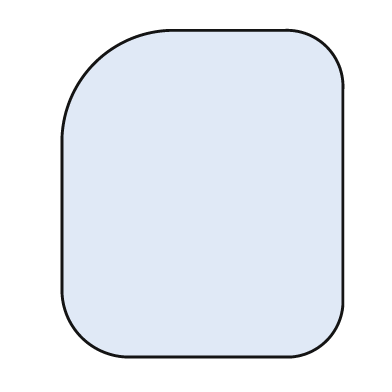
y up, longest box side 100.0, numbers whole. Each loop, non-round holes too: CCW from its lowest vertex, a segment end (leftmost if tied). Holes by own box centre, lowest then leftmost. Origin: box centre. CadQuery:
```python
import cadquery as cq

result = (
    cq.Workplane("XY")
    .moveTo(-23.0, -50.0)
    .lineTo(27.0, -50.0)
    .threePointArc((38.0, -45.0), (43.0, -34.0))
    .lineTo(43.0, 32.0)
    .threePointArc((38.0, 45.0), (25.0, 50.0))
    .lineTo(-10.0, 50.0)
    .threePointArc((-33.0, 40.0), (-43.0, 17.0))
    .lineTo(-43.0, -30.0)
    .threePointArc((-37.0, -44.0), (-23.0, -50.0))
    .close()
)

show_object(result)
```